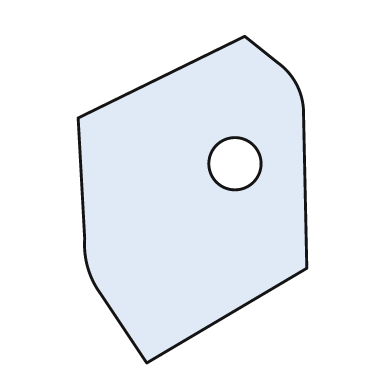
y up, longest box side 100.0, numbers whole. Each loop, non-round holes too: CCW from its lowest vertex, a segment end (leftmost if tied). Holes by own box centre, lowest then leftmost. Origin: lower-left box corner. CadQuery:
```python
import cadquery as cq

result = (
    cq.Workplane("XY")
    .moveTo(21.0, 0.0)
    .lineTo(70.0, 29.0)
    .lineTo(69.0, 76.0)
    .threePointArc((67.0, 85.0), (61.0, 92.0))
    .lineTo(51.0, 100.0)
    .lineTo(0.0, 75.0)
    .lineTo(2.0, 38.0)
    .threePointArc((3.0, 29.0), (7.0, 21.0))
    .close()
    .moveTo(48.0, 61.0)
    .circle(8.0)
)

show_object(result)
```